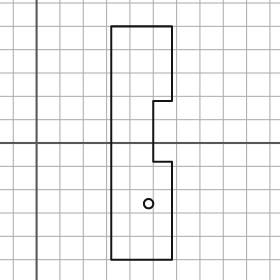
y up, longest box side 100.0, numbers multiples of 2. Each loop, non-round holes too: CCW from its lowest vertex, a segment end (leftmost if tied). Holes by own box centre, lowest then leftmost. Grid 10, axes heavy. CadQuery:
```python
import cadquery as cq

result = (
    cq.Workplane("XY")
    .moveTo(32.0, -50.0)
    .lineTo(58.0, -50.0)
    .lineTo(58.0, -8.0)
    .lineTo(50.0, -8.0)
    .lineTo(50.0, 18.0)
    .lineTo(58.0, 18.0)
    .lineTo(58.0, 50.0)
    .lineTo(32.0, 50.0)
    .close()
    .moveTo(48.0, -26.0)
    .circle(2.0)
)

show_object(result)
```